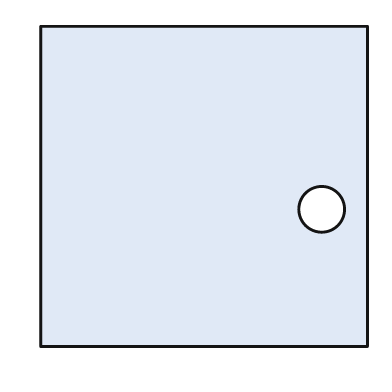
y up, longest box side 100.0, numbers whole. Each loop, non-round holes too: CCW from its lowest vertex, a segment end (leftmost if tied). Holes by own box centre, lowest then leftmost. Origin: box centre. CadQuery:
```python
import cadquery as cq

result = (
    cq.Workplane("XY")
    .moveTo(-50.0, -49.0)
    .lineTo(50.0, -49.0)
    .lineTo(50.0, 49.0)
    .lineTo(-50.0, 49.0)
    .close()
    .moveTo(36.0, -7.0)
    .circle(7.0)
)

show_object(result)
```